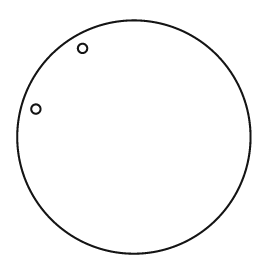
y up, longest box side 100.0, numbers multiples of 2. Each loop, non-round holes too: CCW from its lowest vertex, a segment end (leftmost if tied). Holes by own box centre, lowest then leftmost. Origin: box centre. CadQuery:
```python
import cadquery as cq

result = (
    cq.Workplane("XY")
    .moveTo(0.0, 0.0)
    .circle(50.0)
    .moveTo(-42.0, 12.0)
    .circle(2.0)
    .moveTo(-22.0, 38.0)
    .circle(2.0)
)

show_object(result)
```